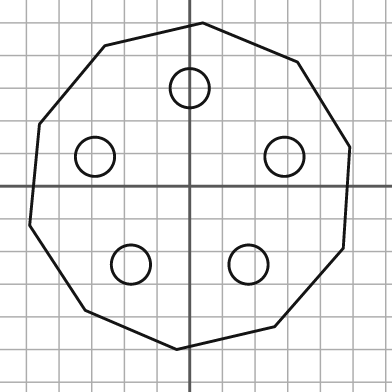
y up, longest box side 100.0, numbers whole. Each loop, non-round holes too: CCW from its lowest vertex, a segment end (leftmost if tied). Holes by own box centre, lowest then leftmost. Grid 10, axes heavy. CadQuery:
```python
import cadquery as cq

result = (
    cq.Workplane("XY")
    .moveTo(-4.0, -50.0)
    .lineTo(26.0, -43.0)
    .lineTo(47.0, -19.0)
    .lineTo(49.0, 12.0)
    .lineTo(33.0, 38.0)
    .lineTo(4.0, 50.0)
    .lineTo(-26.0, 43.0)
    .lineTo(-46.0, 19.0)
    .lineTo(-49.0, -12.0)
    .lineTo(-32.0, -38.0)
    .close()
    .moveTo(-18.0, -24.0)
    .circle(6.0)
    .moveTo(18.0, -24.0)
    .circle(6.0)
    .moveTo(-29.0, 9.0)
    .circle(6.0)
    .moveTo(29.0, 9.0)
    .circle(6.0)
    .moveTo(0.0, 30.0)
    .circle(6.0)
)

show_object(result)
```